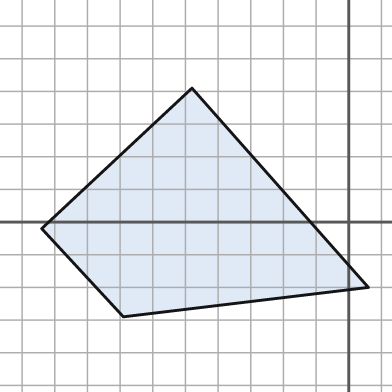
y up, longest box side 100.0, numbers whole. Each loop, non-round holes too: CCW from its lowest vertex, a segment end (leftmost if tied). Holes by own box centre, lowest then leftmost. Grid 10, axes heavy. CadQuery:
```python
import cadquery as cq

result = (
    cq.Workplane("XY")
    .moveTo(-69.0, -29.0)
    .lineTo(6.0, -20.0)
    .lineTo(-48.0, 41.0)
    .lineTo(-94.0, -2.0)
    .close()
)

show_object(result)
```